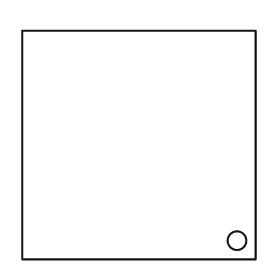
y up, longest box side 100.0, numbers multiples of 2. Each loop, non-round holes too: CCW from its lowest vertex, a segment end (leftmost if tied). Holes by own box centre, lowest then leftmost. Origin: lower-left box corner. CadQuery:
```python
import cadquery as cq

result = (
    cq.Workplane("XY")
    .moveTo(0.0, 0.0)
    .lineTo(100.0, 0.0)
    .lineTo(100.0, 98.0)
    .lineTo(0.0, 98.0)
    .close()
    .moveTo(92.0, 8.0)
    .circle(4.0)
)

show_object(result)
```